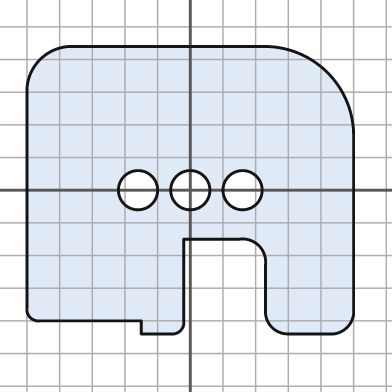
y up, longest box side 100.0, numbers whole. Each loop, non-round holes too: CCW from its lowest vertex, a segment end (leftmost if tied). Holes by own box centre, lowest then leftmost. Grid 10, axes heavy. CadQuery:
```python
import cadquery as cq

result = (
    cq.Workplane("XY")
    .moveTo(-15.0, -44.0)
    .lineTo(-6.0, -44.0)
    .threePointArc((-3.0, -43.0), (-2.0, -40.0))
    .lineTo(-2.0, -15.0)
    .lineTo(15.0, -15.0)
    .threePointArc((21.0, -17.0), (23.0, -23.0))
    .lineTo(23.0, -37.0)
    .threePointArc((25.0, -42.0), (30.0, -44.0))
    .lineTo(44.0, -44.0)
    .threePointArc((48.0, -42.0), (50.0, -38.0))
    .lineTo(50.0, 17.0)
    .threePointArc((42.0, 36.0), (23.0, 44.0))
    .lineTo(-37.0, 44.0)
    .threePointArc((-46.0, 40.0), (-50.0, 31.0))
    .lineTo(-50.0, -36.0)
    .threePointArc((-49.0, -39.0), (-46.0, -40.0))
    .lineTo(-15.0, -40.0)
    .close()
    .moveTo(-16.0, 0.0)
    .circle(6.0)
    .moveTo(0.0, 0.0)
    .circle(6.0)
    .moveTo(16.0, 0.0)
    .circle(6.0)
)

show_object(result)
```